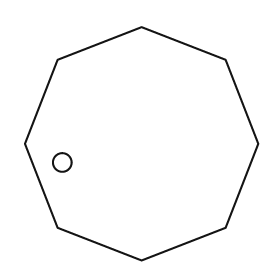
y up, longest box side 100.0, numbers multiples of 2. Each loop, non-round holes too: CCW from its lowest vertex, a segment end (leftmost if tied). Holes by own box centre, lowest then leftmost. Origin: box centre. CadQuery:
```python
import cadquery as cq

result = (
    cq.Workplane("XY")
    .moveTo(0.0, -50.0)
    .lineTo(36.0, -36.0)
    .lineTo(50.0, 0.0)
    .lineTo(36.0, 36.0)
    .lineTo(0.0, 50.0)
    .lineTo(-36.0, 36.0)
    .lineTo(-50.0, 0.0)
    .lineTo(-36.0, -36.0)
    .close()
    .moveTo(-34.0, -8.0)
    .circle(4.0)
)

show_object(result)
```